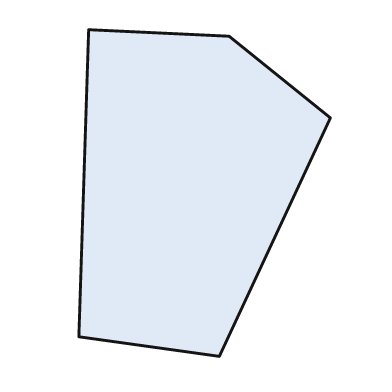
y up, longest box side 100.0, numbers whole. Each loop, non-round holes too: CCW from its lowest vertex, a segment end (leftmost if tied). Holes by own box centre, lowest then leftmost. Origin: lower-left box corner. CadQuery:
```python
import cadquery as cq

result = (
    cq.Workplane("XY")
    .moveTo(43.0, 0.0)
    .lineTo(77.0, 73.0)
    .lineTo(46.0, 98.0)
    .lineTo(3.0, 100.0)
    .lineTo(0.0, 6.0)
    .close()
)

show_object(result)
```